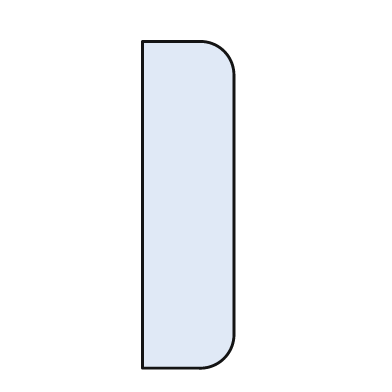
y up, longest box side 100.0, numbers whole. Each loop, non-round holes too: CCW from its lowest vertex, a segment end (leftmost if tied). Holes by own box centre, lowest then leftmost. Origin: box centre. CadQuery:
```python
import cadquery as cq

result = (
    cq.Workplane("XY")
    .moveTo(-14.0, -50.0)
    .lineTo(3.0, -50.0)
    .threePointArc((11.0, -47.0), (14.0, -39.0))
    .lineTo(14.0, 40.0)
    .threePointArc((11.0, 47.0), (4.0, 50.0))
    .lineTo(-14.0, 50.0)
    .close()
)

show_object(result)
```